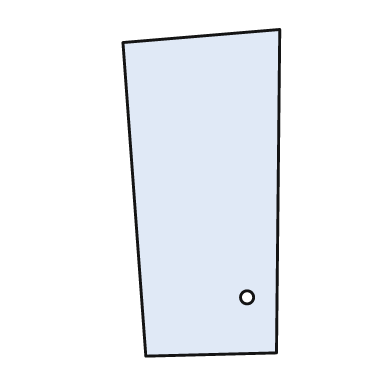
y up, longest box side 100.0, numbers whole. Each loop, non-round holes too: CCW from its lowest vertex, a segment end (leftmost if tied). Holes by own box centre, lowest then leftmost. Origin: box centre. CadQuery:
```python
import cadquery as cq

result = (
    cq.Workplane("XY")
    .moveTo(-17.0, -50.0)
    .lineTo(23.0, -49.0)
    .lineTo(24.0, 50.0)
    .lineTo(-24.0, 46.0)
    .close()
    .moveTo(14.0, -32.0)
    .circle(2.0)
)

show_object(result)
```